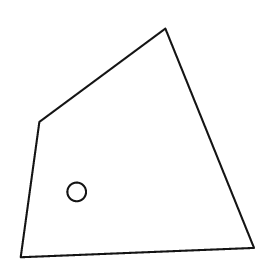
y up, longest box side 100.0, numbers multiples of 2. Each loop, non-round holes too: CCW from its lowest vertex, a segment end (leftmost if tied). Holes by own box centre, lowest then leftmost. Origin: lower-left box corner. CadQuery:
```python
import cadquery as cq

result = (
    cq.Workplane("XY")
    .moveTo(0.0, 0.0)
    .lineTo(100.0, 4.0)
    .lineTo(62.0, 98.0)
    .lineTo(8.0, 58.0)
    .close()
    .moveTo(24.0, 28.0)
    .circle(4.0)
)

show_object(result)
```